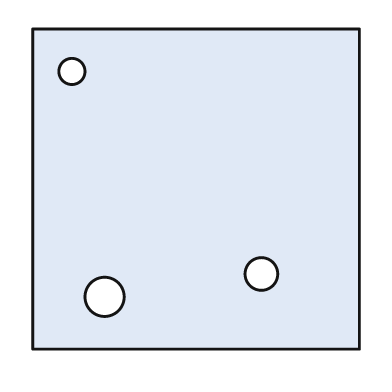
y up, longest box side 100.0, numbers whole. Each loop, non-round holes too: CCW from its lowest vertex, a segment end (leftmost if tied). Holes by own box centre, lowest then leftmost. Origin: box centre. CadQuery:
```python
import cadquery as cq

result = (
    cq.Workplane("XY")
    .moveTo(-50.0, -49.0)
    .lineTo(50.0, -49.0)
    .lineTo(50.0, 49.0)
    .lineTo(-50.0, 49.0)
    .close()
    .moveTo(-28.0, -33.0)
    .circle(6.0)
    .moveTo(20.0, -26.0)
    .circle(5.0)
    .moveTo(-38.0, 36.0)
    .circle(4.0)
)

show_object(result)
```